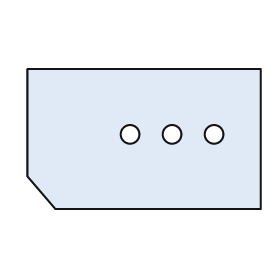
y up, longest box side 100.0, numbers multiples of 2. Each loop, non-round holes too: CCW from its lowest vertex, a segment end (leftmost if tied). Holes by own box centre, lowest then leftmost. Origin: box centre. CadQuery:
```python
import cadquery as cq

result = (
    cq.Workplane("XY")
    .moveTo(-38.0, -30.0)
    .lineTo(50.0, -30.0)
    .lineTo(50.0, 30.0)
    .lineTo(-50.0, 30.0)
    .lineTo(-50.0, -16.0)
    .close()
    .moveTo(-6.0, 2.0)
    .circle(4.0)
    .moveTo(12.0, 2.0)
    .circle(4.0)
    .moveTo(30.0, 2.0)
    .circle(4.0)
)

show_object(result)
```